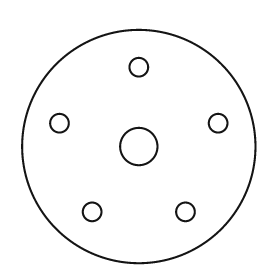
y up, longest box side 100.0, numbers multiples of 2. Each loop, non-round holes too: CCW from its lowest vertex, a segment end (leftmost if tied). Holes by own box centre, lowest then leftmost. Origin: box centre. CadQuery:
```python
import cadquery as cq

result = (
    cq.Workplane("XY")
    .moveTo(0.0, 0.0)
    .circle(50.0)
    .moveTo(-20.0, -28.0)
    .circle(4.0)
    .moveTo(20.0, -28.0)
    .circle(4.0)
    .moveTo(0.0, 0.0)
    .circle(8.0)
    .moveTo(-34.0, 10.0)
    .circle(4.0)
    .moveTo(34.0, 10.0)
    .circle(4.0)
    .moveTo(0.0, 34.0)
    .circle(4.0)
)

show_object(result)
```